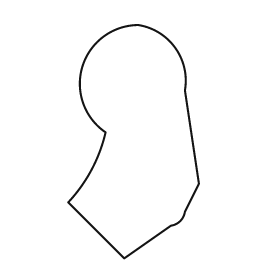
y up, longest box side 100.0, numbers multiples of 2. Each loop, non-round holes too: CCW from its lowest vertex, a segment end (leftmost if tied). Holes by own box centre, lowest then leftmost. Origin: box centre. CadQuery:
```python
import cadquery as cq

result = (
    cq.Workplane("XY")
    .moveTo(-4.0, -50.0)
    .lineTo(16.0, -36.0)
    .threePointArc((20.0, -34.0), (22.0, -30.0))
    .lineTo(28.0, -18.0)
    .lineTo(22.0, 22.0)
    .threePointArc((18.0, 40.0), (2.0, 50.0))
    .threePointArc((-22.0, 32.0), (-12.0, 4.0))
    .threePointArc((-18.0, -12.0), (-28.0, -26.0))
    .close()
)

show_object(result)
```